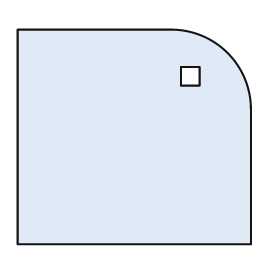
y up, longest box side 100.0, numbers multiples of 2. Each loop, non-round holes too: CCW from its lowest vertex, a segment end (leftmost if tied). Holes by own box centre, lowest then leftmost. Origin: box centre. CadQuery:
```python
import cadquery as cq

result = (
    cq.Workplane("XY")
    .moveTo(-50.0, -46.0)
    .lineTo(50.0, -46.0)
    .lineTo(50.0, 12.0)
    .threePointArc((40.0, 36.0), (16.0, 46.0))
    .lineTo(-50.0, 46.0)
    .close()
    .moveTo(20.0, 22.0)
    .lineTo(28.0, 22.0)
    .lineTo(28.0, 30.0)
    .lineTo(20.0, 30.0)
    .close()
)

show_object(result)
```